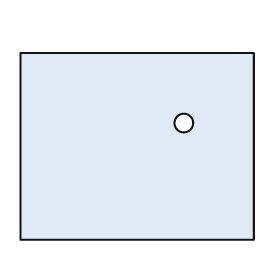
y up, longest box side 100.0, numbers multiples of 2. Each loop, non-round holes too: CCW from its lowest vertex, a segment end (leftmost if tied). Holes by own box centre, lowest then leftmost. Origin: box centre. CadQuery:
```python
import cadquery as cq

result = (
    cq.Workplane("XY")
    .moveTo(-50.0, -40.0)
    .lineTo(50.0, -40.0)
    .lineTo(50.0, 40.0)
    .lineTo(-50.0, 40.0)
    .close()
    .moveTo(20.0, 10.0)
    .circle(4.0)
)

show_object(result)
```